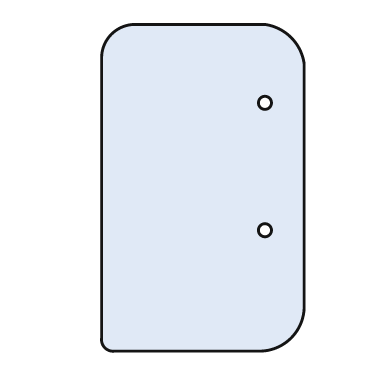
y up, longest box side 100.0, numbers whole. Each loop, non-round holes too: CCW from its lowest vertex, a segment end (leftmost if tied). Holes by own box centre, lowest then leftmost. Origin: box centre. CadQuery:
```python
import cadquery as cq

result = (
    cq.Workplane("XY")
    .moveTo(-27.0, -50.0)
    .lineTo(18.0, -50.0)
    .threePointArc((27.0, -46.0), (31.0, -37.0))
    .lineTo(31.0, 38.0)
    .threePointArc((27.0, 46.0), (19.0, 50.0))
    .lineTo(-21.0, 50.0)
    .threePointArc((-28.0, 47.0), (-31.0, 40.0))
    .lineTo(-31.0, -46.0)
    .threePointArc((-30.0, -49.0), (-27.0, -50.0))
    .close()
    .moveTo(19.0, -13.0)
    .circle(2.0)
    .moveTo(19.0, 26.0)
    .circle(2.0)
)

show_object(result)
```